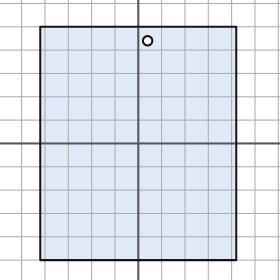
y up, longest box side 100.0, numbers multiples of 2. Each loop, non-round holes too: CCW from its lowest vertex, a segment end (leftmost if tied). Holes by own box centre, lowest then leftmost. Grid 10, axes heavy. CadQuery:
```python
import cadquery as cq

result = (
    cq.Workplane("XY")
    .moveTo(-42.0, -50.0)
    .lineTo(42.0, -50.0)
    .lineTo(42.0, 50.0)
    .lineTo(-42.0, 50.0)
    .close()
    .moveTo(4.0, 44.0)
    .circle(2.0)
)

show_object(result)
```